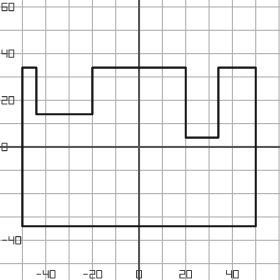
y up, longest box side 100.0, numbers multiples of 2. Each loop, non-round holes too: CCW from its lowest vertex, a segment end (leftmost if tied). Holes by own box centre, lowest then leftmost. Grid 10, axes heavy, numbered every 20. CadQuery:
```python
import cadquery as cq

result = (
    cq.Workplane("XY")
    .moveTo(-50.0, -34.0)
    .lineTo(50.0, -34.0)
    .lineTo(50.0, 34.0)
    .lineTo(34.0, 34.0)
    .lineTo(34.0, 4.0)
    .lineTo(20.0, 4.0)
    .lineTo(20.0, 34.0)
    .lineTo(-20.0, 34.0)
    .lineTo(-20.0, 14.0)
    .lineTo(-44.0, 14.0)
    .lineTo(-44.0, 34.0)
    .lineTo(-50.0, 34.0)
    .close()
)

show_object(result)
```